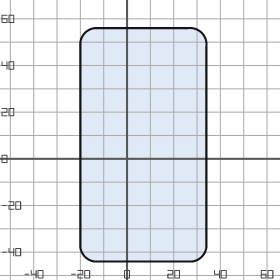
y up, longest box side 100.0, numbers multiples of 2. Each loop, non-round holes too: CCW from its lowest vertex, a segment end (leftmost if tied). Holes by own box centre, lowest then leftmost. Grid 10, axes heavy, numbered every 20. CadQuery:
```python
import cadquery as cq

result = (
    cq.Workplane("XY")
    .moveTo(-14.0, -44.0)
    .lineTo(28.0, -44.0)
    .threePointArc((32.0, -42.0), (34.0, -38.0))
    .lineTo(34.0, 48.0)
    .threePointArc((32.0, 54.0), (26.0, 56.0))
    .lineTo(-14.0, 56.0)
    .threePointArc((-18.0, 54.0), (-20.0, 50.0))
    .lineTo(-20.0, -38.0)
    .threePointArc((-18.0, -42.0), (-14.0, -44.0))
    .close()
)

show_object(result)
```